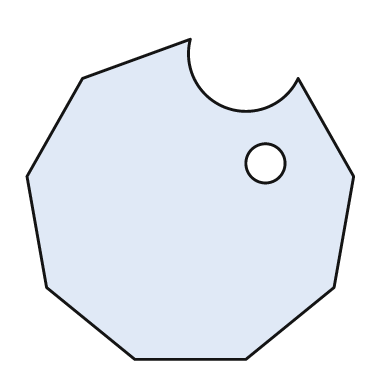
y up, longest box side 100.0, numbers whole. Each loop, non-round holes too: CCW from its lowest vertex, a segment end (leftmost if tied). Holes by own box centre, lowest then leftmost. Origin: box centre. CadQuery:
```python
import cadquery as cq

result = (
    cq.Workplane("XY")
    .moveTo(-17.0, -49.0)
    .lineTo(17.0, -49.0)
    .lineTo(44.0, -27.0)
    .lineTo(50.0, 7.0)
    .lineTo(33.0, 37.0)
    .threePointArc((11.0, 28.0), (0.0, 49.0))
    .lineTo(-33.0, 37.0)
    .lineTo(-50.0, 7.0)
    .lineTo(-44.0, -27.0)
    .close()
    .moveTo(23.0, 11.0)
    .circle(6.0)
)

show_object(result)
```